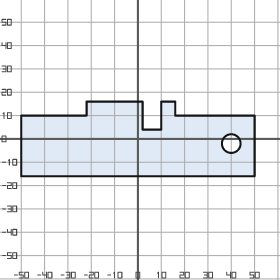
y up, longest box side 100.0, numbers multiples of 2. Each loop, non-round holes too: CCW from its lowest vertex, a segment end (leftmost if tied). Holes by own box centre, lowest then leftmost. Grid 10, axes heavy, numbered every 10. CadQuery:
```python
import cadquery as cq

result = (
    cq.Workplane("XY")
    .moveTo(-50.0, -16.0)
    .lineTo(50.0, -16.0)
    .lineTo(50.0, 10.0)
    .lineTo(16.0, 10.0)
    .lineTo(16.0, 16.0)
    .lineTo(10.0, 16.0)
    .lineTo(10.0, 4.0)
    .lineTo(2.0, 4.0)
    .lineTo(2.0, 16.0)
    .lineTo(-22.0, 16.0)
    .lineTo(-22.0, 10.0)
    .lineTo(-50.0, 10.0)
    .close()
    .moveTo(40.0, -2.0)
    .circle(4.0)
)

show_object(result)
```